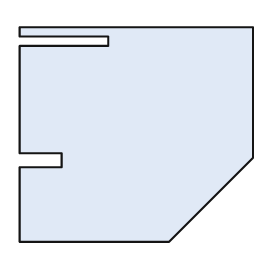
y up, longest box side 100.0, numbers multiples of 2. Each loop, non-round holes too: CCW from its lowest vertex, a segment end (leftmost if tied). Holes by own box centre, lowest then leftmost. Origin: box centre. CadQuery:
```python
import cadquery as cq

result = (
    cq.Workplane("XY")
    .moveTo(-50.0, -46.0)
    .lineTo(14.0, -46.0)
    .lineTo(50.0, -10.0)
    .lineTo(50.0, 46.0)
    .lineTo(-50.0, 46.0)
    .lineTo(-50.0, 42.0)
    .lineTo(-12.0, 42.0)
    .lineTo(-12.0, 38.0)
    .lineTo(-50.0, 38.0)
    .lineTo(-50.0, -8.0)
    .lineTo(-32.0, -8.0)
    .lineTo(-32.0, -14.0)
    .lineTo(-50.0, -14.0)
    .close()
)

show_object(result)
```